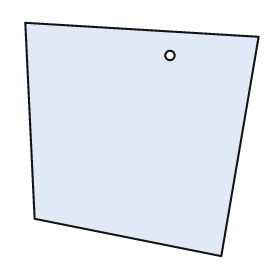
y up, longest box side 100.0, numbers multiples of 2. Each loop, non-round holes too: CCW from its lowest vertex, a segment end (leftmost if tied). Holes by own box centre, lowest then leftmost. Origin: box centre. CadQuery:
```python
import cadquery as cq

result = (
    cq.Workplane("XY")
    .moveTo(34.0, -50.0)
    .lineTo(50.0, 44.0)
    .lineTo(-50.0, 50.0)
    .lineTo(-46.0, -34.0)
    .close()
    .moveTo(12.0, 36.0)
    .circle(2.0)
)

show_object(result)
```